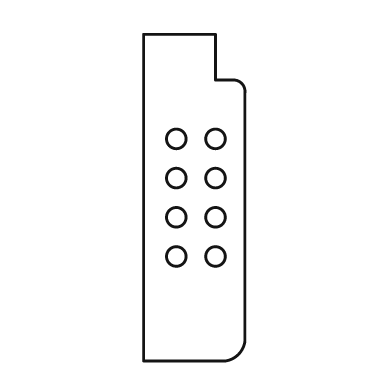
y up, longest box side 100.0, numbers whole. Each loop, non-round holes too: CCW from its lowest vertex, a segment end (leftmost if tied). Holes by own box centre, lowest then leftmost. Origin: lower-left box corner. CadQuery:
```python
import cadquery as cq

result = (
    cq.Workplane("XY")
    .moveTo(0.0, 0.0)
    .lineTo(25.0, 0.0)
    .threePointArc((29.0, 2.0), (31.0, 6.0))
    .lineTo(31.0, 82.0)
    .threePointArc((30.0, 85.0), (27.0, 86.0))
    .lineTo(22.0, 86.0)
    .lineTo(22.0, 100.0)
    .lineTo(0.0, 100.0)
    .close()
    .moveTo(10.0, 32.0)
    .circle(3.0)
    .moveTo(22.0, 32.0)
    .circle(3.0)
    .moveTo(10.0, 44.0)
    .circle(3.0)
    .moveTo(22.0, 44.0)
    .circle(3.0)
    .moveTo(10.0, 56.0)
    .circle(3.0)
    .moveTo(22.0, 56.0)
    .circle(3.0)
    .moveTo(10.0, 68.0)
    .circle(3.0)
    .moveTo(22.0, 68.0)
    .circle(3.0)
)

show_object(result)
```